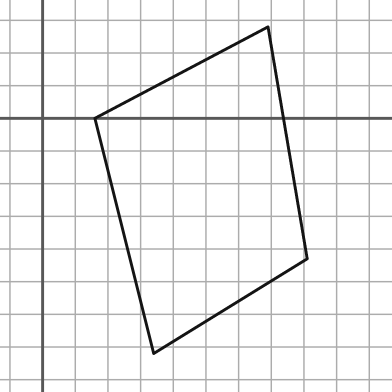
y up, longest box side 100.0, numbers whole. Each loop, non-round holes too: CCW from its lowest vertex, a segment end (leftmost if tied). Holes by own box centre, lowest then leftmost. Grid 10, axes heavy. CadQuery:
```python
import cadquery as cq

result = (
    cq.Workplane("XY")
    .moveTo(34.0, -72.0)
    .lineTo(81.0, -43.0)
    .lineTo(69.0, 28.0)
    .lineTo(16.0, 0.0)
    .close()
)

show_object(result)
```